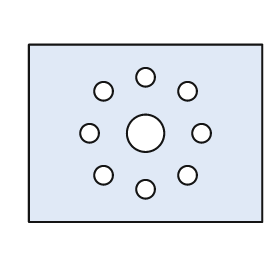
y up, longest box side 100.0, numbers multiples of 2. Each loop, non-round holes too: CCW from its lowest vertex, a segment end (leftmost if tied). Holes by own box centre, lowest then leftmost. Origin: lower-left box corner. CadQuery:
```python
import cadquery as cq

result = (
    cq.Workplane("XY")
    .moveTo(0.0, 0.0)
    .lineTo(100.0, 0.0)
    .lineTo(100.0, 76.0)
    .lineTo(0.0, 76.0)
    .close()
    .moveTo(50.0, 14.0)
    .circle(4.0)
    .moveTo(32.0, 20.0)
    .circle(4.0)
    .moveTo(68.0, 20.0)
    .circle(4.0)
    .moveTo(26.0, 38.0)
    .circle(4.0)
    .moveTo(50.0, 38.0)
    .circle(8.0)
    .moveTo(74.0, 38.0)
    .circle(4.0)
    .moveTo(32.0, 56.0)
    .circle(4.0)
    .moveTo(68.0, 56.0)
    .circle(4.0)
    .moveTo(50.0, 62.0)
    .circle(4.0)
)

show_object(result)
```